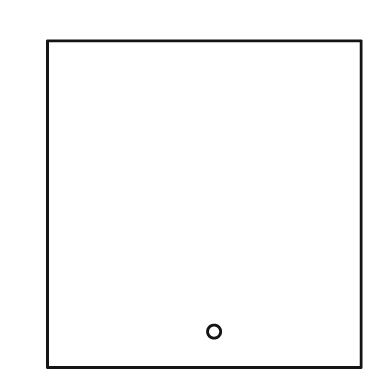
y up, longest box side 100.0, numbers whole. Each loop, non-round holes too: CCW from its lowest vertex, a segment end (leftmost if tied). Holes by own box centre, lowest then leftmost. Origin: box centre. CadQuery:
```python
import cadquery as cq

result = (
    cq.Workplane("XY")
    .moveTo(-48.0, -50.0)
    .lineTo(48.0, -50.0)
    .lineTo(48.0, 50.0)
    .lineTo(-48.0, 50.0)
    .close()
    .moveTo(3.0, -39.0)
    .circle(2.0)
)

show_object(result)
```